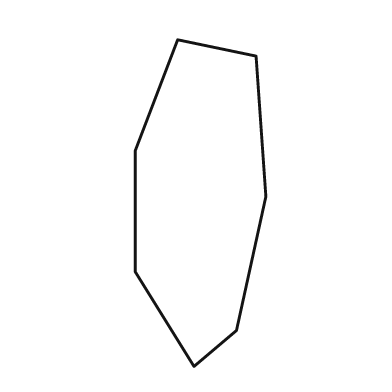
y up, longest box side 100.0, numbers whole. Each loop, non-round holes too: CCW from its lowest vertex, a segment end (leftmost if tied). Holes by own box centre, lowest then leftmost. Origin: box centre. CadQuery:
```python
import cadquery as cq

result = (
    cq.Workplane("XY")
    .moveTo(-2.0, -50.0)
    .lineTo(11.0, -39.0)
    .lineTo(20.0, 2.0)
    .lineTo(17.0, 45.0)
    .lineTo(-7.0, 50.0)
    .lineTo(-20.0, 16.0)
    .lineTo(-20.0, -21.0)
    .close()
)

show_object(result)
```